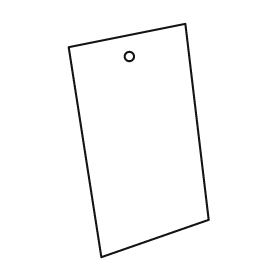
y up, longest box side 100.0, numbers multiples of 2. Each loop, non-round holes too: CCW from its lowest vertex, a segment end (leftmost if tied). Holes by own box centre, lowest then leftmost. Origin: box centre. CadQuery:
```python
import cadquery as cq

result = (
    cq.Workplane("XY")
    .moveTo(-16.0, -50.0)
    .lineTo(30.0, -34.0)
    .lineTo(20.0, 50.0)
    .lineTo(-30.0, 40.0)
    .close()
    .moveTo(-4.0, 36.0)
    .circle(2.0)
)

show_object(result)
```